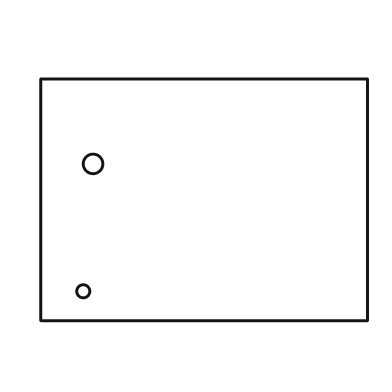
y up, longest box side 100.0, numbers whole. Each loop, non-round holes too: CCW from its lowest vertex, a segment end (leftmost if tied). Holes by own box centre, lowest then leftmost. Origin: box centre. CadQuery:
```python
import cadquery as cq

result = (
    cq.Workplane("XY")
    .moveTo(-50.0, -37.0)
    .lineTo(50.0, -37.0)
    .lineTo(50.0, 37.0)
    .lineTo(-50.0, 37.0)
    .close()
    .moveTo(-37.0, -28.0)
    .circle(2.0)
    .moveTo(-34.0, 11.0)
    .circle(3.0)
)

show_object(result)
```